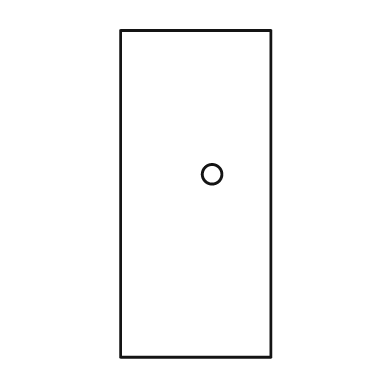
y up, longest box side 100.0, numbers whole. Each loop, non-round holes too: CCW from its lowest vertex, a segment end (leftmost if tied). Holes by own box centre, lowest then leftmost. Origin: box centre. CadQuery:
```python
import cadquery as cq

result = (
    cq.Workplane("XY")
    .moveTo(-23.0, -50.0)
    .lineTo(23.0, -50.0)
    .lineTo(23.0, 50.0)
    .lineTo(-23.0, 50.0)
    .close()
    .moveTo(5.0, 6.0)
    .circle(3.0)
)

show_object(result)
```